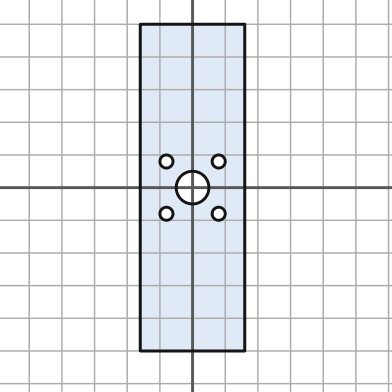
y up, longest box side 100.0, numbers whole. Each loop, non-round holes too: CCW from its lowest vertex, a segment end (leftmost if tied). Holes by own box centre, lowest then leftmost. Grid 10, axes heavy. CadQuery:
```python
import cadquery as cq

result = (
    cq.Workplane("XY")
    .moveTo(-16.0, -50.0)
    .lineTo(16.0, -50.0)
    .lineTo(16.0, 50.0)
    .lineTo(-16.0, 50.0)
    .close()
    .moveTo(-8.0, -8.0)
    .circle(2.0)
    .moveTo(8.0, -8.0)
    .circle(2.0)
    .moveTo(0.0, 0.0)
    .circle(5.0)
    .moveTo(-8.0, 8.0)
    .circle(2.0)
    .moveTo(8.0, 8.0)
    .circle(2.0)
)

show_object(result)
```